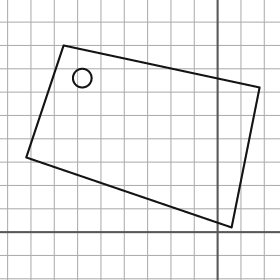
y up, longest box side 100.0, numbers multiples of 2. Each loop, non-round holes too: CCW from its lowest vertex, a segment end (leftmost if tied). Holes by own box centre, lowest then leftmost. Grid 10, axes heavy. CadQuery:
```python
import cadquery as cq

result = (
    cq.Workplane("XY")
    .moveTo(6.0, 2.0)
    .lineTo(18.0, 62.0)
    .lineTo(-66.0, 80.0)
    .lineTo(-82.0, 32.0)
    .close()
    .moveTo(-58.0, 66.0)
    .circle(4.0)
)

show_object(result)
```